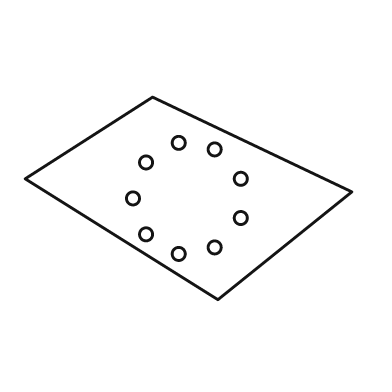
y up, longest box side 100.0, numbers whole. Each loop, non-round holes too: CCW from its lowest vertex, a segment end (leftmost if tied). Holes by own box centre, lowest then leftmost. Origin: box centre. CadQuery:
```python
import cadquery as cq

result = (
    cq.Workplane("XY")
    .moveTo(9.0, -31.0)
    .lineTo(50.0, 2.0)
    .lineTo(-11.0, 31.0)
    .lineTo(-50.0, 6.0)
    .close()
    .moveTo(-3.0, -17.0)
    .circle(2.0)
    .moveTo(8.0, -15.0)
    .circle(2.0)
    .moveTo(-13.0, -11.0)
    .circle(2.0)
    .moveTo(16.0, -6.0)
    .circle(2.0)
    .moveTo(-17.0, 0.0)
    .circle(2.0)
    .moveTo(16.0, 6.0)
    .circle(2.0)
    .moveTo(-13.0, 11.0)
    .circle(2.0)
    .moveTo(8.0, 15.0)
    .circle(2.0)
    .moveTo(-3.0, 17.0)
    .circle(2.0)
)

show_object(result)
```